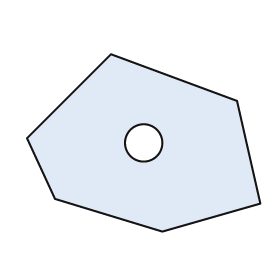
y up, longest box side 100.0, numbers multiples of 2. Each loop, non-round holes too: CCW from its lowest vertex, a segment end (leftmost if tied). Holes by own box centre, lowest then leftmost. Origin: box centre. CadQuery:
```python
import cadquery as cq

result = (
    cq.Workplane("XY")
    .moveTo(8.0, -38.0)
    .lineTo(50.0, -26.0)
    .lineTo(40.0, 18.0)
    .lineTo(-14.0, 38.0)
    .lineTo(-50.0, 2.0)
    .lineTo(-38.0, -24.0)
    .close()
    .moveTo(0.0, 0.0)
    .circle(8.0)
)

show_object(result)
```